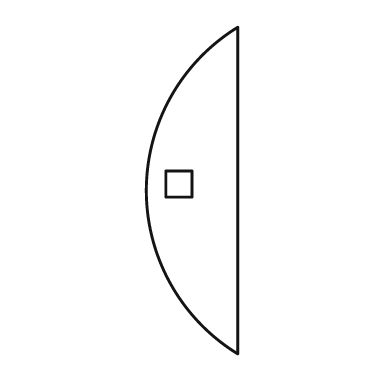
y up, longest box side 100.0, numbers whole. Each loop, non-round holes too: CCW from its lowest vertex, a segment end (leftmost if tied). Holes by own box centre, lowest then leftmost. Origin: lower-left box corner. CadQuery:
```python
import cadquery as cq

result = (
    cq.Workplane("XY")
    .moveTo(28.0, 0.0)
    .lineTo(28.0, 100.0)
    .threePointArc((0.0, 50.0), (28.0, 0.0))
    .close()
    .moveTo(6.0, 48.0)
    .lineTo(14.0, 48.0)
    .lineTo(14.0, 56.0)
    .lineTo(6.0, 56.0)
    .close()
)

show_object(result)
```